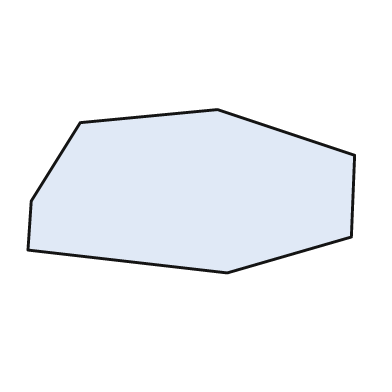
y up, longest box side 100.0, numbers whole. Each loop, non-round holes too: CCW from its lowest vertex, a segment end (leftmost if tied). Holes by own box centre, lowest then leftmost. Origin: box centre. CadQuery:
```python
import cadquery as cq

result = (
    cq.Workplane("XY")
    .moveTo(11.0, -25.0)
    .lineTo(49.0, -14.0)
    .lineTo(50.0, 11.0)
    .lineTo(8.0, 25.0)
    .lineTo(-34.0, 21.0)
    .lineTo(-49.0, -3.0)
    .lineTo(-50.0, -18.0)
    .close()
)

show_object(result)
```